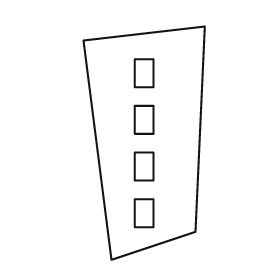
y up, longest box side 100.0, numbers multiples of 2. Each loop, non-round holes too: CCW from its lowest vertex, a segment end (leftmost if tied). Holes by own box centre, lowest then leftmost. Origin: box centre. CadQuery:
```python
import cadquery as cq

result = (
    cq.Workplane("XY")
    .moveTo(-14.0, -50.0)
    .lineTo(22.0, -38.0)
    .lineTo(26.0, 50.0)
    .lineTo(-26.0, 44.0)
    .close()
    .moveTo(-4.0, -36.0)
    .lineTo(4.0, -36.0)
    .lineTo(4.0, -24.0)
    .lineTo(-4.0, -24.0)
    .close()
    .moveTo(-4.0, -16.0)
    .lineTo(4.0, -16.0)
    .lineTo(4.0, -4.0)
    .lineTo(-4.0, -4.0)
    .close()
    .moveTo(-4.0, 4.0)
    .lineTo(4.0, 4.0)
    .lineTo(4.0, 16.0)
    .lineTo(-4.0, 16.0)
    .close()
    .moveTo(-4.0, 24.0)
    .lineTo(4.0, 24.0)
    .lineTo(4.0, 36.0)
    .lineTo(-4.0, 36.0)
    .close()
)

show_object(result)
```